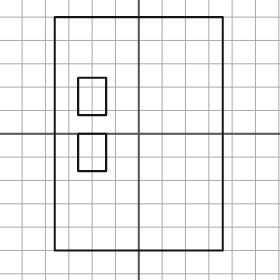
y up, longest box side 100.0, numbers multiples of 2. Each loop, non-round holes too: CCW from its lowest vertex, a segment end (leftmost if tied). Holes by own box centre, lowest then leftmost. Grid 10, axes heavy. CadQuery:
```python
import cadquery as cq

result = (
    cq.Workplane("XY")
    .moveTo(-36.0, -50.0)
    .lineTo(36.0, -50.0)
    .lineTo(36.0, 50.0)
    .lineTo(-36.0, 50.0)
    .close()
    .moveTo(-26.0, -16.0)
    .lineTo(-14.0, -16.0)
    .lineTo(-14.0, 0.0)
    .lineTo(-26.0, 0.0)
    .close()
    .moveTo(-26.0, 8.0)
    .lineTo(-14.0, 8.0)
    .lineTo(-14.0, 24.0)
    .lineTo(-26.0, 24.0)
    .close()
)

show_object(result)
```